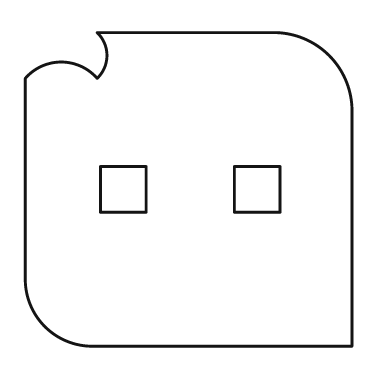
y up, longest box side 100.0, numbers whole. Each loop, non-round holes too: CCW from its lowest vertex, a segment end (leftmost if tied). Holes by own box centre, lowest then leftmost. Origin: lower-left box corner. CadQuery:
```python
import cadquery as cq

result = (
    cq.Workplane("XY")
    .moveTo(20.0, 0.0)
    .lineTo(100.0, 0.0)
    .lineTo(100.0, 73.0)
    .threePointArc((93.0, 89.0), (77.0, 96.0))
    .lineTo(22.0, 96.0)
    .threePointArc((25.0, 89.0), (22.0, 82.0))
    .threePointArc((11.0, 87.0), (0.0, 82.0))
    .lineTo(0.0, 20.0)
    .threePointArc((6.0, 6.0), (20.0, 0.0))
    .close()
    .moveTo(23.0, 41.0)
    .lineTo(37.0, 41.0)
    .lineTo(37.0, 55.0)
    .lineTo(23.0, 55.0)
    .close()
    .moveTo(64.0, 41.0)
    .lineTo(78.0, 41.0)
    .lineTo(78.0, 55.0)
    .lineTo(64.0, 55.0)
    .close()
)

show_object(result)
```